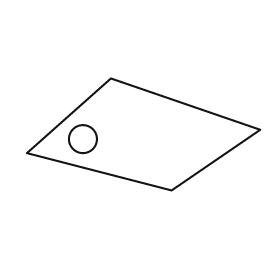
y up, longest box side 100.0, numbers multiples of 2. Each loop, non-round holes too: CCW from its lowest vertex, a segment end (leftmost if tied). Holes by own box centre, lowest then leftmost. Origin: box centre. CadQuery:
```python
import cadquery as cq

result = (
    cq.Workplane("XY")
    .moveTo(12.0, -24.0)
    .lineTo(50.0, 2.0)
    .lineTo(-14.0, 24.0)
    .lineTo(-50.0, -8.0)
    .close()
    .moveTo(-26.0, -2.0)
    .circle(6.0)
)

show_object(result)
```